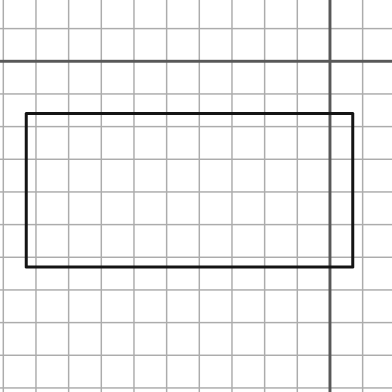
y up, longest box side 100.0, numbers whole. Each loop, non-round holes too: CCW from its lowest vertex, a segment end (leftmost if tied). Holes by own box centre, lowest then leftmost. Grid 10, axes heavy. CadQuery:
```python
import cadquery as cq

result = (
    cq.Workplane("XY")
    .moveTo(-93.0, -63.0)
    .lineTo(7.0, -63.0)
    .lineTo(7.0, -16.0)
    .lineTo(-93.0, -16.0)
    .close()
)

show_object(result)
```